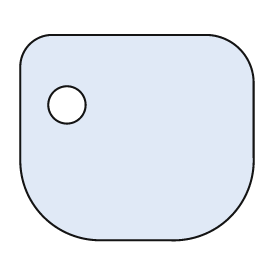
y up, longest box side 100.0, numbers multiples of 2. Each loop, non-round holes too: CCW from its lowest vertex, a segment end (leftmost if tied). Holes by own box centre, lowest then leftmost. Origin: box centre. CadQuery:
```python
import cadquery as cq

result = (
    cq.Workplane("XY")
    .moveTo(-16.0, -44.0)
    .lineTo(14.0, -44.0)
    .threePointArc((40.0, -34.0), (50.0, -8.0))
    .lineTo(50.0, 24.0)
    .threePointArc((44.0, 38.0), (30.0, 44.0))
    .lineTo(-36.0, 44.0)
    .threePointArc((-46.0, 40.0), (-50.0, 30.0))
    .lineTo(-50.0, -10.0)
    .threePointArc((-40.0, -34.0), (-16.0, -44.0))
    .close()
    .moveTo(-30.0, 14.0)
    .circle(8.0)
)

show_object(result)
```